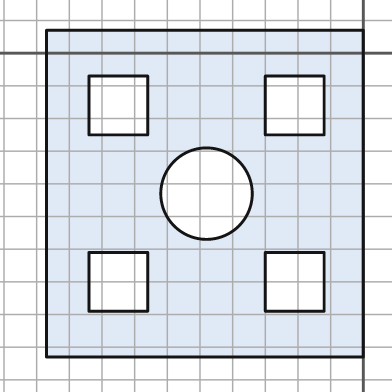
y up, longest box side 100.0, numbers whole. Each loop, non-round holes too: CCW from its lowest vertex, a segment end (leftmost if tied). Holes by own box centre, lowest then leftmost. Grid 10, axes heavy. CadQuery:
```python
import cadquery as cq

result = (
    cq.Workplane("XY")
    .moveTo(-97.0, -93.0)
    .lineTo(0.0, -93.0)
    .lineTo(0.0, 7.0)
    .lineTo(-97.0, 7.0)
    .close()
    .moveTo(-84.0, -79.0)
    .lineTo(-66.0, -79.0)
    .lineTo(-66.0, -61.0)
    .lineTo(-84.0, -61.0)
    .close()
    .moveTo(-30.0, -79.0)
    .lineTo(-12.0, -79.0)
    .lineTo(-12.0, -61.0)
    .lineTo(-30.0, -61.0)
    .close()
    .moveTo(-48.0, -43.0)
    .circle(14.0)
    .moveTo(-84.0, -25.0)
    .lineTo(-66.0, -25.0)
    .lineTo(-66.0, -7.0)
    .lineTo(-84.0, -7.0)
    .close()
    .moveTo(-30.0, -25.0)
    .lineTo(-12.0, -25.0)
    .lineTo(-12.0, -7.0)
    .lineTo(-30.0, -7.0)
    .close()
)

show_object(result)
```